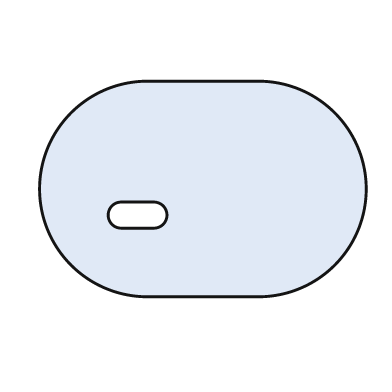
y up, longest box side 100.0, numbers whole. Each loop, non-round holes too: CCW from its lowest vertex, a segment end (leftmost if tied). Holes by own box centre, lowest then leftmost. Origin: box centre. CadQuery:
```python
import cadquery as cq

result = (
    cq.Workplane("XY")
    .moveTo(-17.0, -33.0)
    .lineTo(17.0, -33.0)
    .threePointArc((50.0, 0.0), (17.0, 33.0))
    .lineTo(-17.0, 33.0)
    .threePointArc((-50.0, 0.0), (-17.0, -33.0))
    .close()
    .moveTo(-25.0, -12.0)
    .lineTo(-15.0, -12.0)
    .threePointArc((-11.0, -8.0), (-15.0, -4.0))
    .lineTo(-25.0, -4.0)
    .threePointArc((-29.0, -8.0), (-25.0, -12.0))
    .close()
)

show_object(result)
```